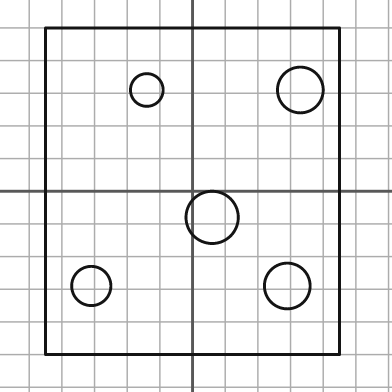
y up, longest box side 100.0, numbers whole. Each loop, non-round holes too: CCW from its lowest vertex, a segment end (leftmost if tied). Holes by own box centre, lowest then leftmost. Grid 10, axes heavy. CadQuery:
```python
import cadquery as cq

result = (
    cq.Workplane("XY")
    .moveTo(-45.0, -50.0)
    .lineTo(45.0, -50.0)
    .lineTo(45.0, 50.0)
    .lineTo(-45.0, 50.0)
    .close()
    .moveTo(-31.0, -29.0)
    .circle(6.0)
    .moveTo(29.0, -29.0)
    .circle(7.0)
    .moveTo(6.0, -8.0)
    .circle(8.0)
    .moveTo(-14.0, 31.0)
    .circle(5.0)
    .moveTo(33.0, 31.0)
    .circle(7.0)
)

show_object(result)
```